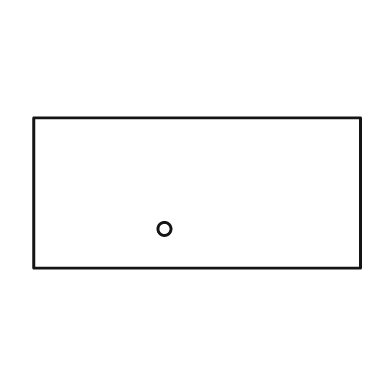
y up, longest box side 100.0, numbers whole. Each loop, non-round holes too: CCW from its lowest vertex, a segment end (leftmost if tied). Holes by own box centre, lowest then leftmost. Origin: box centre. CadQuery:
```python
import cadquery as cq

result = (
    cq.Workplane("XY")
    .moveTo(-50.0, -23.0)
    .lineTo(50.0, -23.0)
    .lineTo(50.0, 23.0)
    .lineTo(-50.0, 23.0)
    .close()
    .moveTo(-10.0, -11.0)
    .circle(2.0)
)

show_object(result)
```